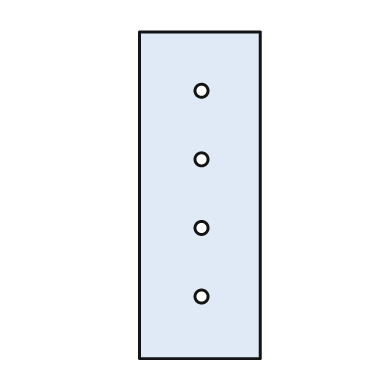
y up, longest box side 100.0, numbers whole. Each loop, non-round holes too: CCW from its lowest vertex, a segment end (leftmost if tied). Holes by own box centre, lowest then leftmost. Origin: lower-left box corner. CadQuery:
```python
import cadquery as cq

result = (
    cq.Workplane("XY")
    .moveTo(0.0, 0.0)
    .lineTo(37.0, 0.0)
    .lineTo(37.0, 100.0)
    .lineTo(0.0, 100.0)
    .close()
    .moveTo(19.0, 19.0)
    .circle(2.0)
    .moveTo(19.0, 40.0)
    .circle(2.0)
    .moveTo(19.0, 61.0)
    .circle(2.0)
    .moveTo(19.0, 82.0)
    .circle(2.0)
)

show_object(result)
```